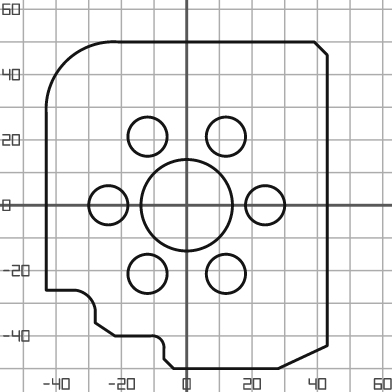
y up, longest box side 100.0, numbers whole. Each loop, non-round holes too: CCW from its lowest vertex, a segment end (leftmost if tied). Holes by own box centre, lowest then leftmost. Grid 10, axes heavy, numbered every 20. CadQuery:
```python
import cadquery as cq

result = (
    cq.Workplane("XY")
    .moveTo(-4.0, -50.0)
    .lineTo(28.0, -50.0)
    .lineTo(43.0, -43.0)
    .lineTo(43.0, 46.0)
    .lineTo(39.0, 50.0)
    .lineTo(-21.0, 50.0)
    .threePointArc((-37.0, 44.0), (-43.0, 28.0))
    .lineTo(-43.0, -26.0)
    .lineTo(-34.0, -26.0)
    .threePointArc((-30.0, -28.0), (-28.0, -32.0))
    .lineTo(-28.0, -36.0)
    .lineTo(-22.0, -40.0)
    .lineTo(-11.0, -40.0)
    .threePointArc((-8.0, -41.0), (-7.0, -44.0))
    .lineTo(-7.0, -47.0)
    .close()
    .moveTo(-12.0, -21.0)
    .circle(6.0)
    .moveTo(12.0, -21.0)
    .circle(6.0)
    .moveTo(-24.0, 0.0)
    .circle(6.0)
    .moveTo(0.0, 0.0)
    .circle(14.0)
    .moveTo(24.0, 0.0)
    .circle(6.0)
    .moveTo(-12.0, 21.0)
    .circle(6.0)
    .moveTo(12.0, 21.0)
    .circle(6.0)
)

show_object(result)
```